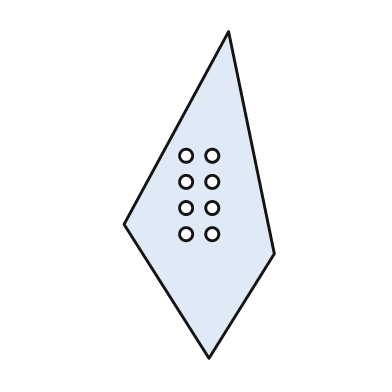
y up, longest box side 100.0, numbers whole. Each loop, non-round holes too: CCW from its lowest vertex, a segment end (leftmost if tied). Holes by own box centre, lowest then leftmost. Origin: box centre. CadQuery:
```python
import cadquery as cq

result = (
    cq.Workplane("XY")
    .moveTo(3.0, -50.0)
    .lineTo(23.0, -18.0)
    .lineTo(9.0, 50.0)
    .lineTo(-23.0, -9.0)
    .close()
    .moveTo(-4.0, -12.0)
    .circle(2.0)
    .moveTo(4.0, -12.0)
    .circle(2.0)
    .moveTo(-4.0, -4.0)
    .circle(2.0)
    .moveTo(4.0, -4.0)
    .circle(2.0)
    .moveTo(-4.0, 4.0)
    .circle(2.0)
    .moveTo(4.0, 4.0)
    .circle(2.0)
    .moveTo(-4.0, 12.0)
    .circle(2.0)
    .moveTo(4.0, 12.0)
    .circle(2.0)
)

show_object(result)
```